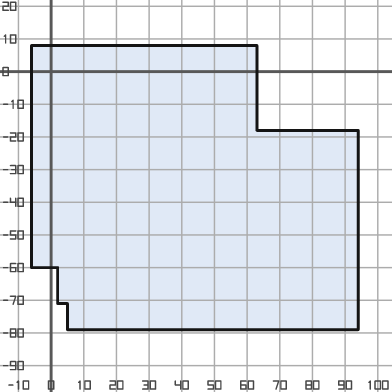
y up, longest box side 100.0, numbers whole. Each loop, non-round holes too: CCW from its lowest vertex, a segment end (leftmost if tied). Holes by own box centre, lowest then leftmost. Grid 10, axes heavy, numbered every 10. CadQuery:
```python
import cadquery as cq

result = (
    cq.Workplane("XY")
    .moveTo(5.0, -79.0)
    .lineTo(94.0, -79.0)
    .lineTo(94.0, -18.0)
    .lineTo(63.0, -18.0)
    .lineTo(63.0, 8.0)
    .lineTo(-6.0, 8.0)
    .lineTo(-6.0, -60.0)
    .lineTo(2.0, -60.0)
    .lineTo(2.0, -71.0)
    .lineTo(5.0, -71.0)
    .close()
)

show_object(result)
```